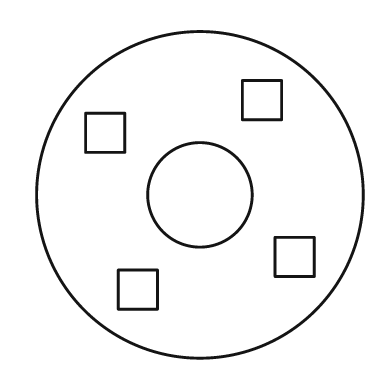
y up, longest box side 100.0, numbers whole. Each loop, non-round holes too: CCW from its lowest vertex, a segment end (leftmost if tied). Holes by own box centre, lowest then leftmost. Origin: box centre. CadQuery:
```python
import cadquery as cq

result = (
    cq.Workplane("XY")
    .moveTo(0.0, 0.0)
    .circle(50.0)
    .moveTo(-25.0, -35.0)
    .lineTo(-13.0, -35.0)
    .lineTo(-13.0, -23.0)
    .lineTo(-25.0, -23.0)
    .close()
    .moveTo(23.0, -25.0)
    .lineTo(35.0, -25.0)
    .lineTo(35.0, -13.0)
    .lineTo(23.0, -13.0)
    .close()
    .moveTo(0.0, 0.0)
    .circle(16.0)
    .moveTo(-35.0, 13.0)
    .lineTo(-23.0, 13.0)
    .lineTo(-23.0, 25.0)
    .lineTo(-35.0, 25.0)
    .close()
    .moveTo(13.0, 23.0)
    .lineTo(25.0, 23.0)
    .lineTo(25.0, 35.0)
    .lineTo(13.0, 35.0)
    .close()
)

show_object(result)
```